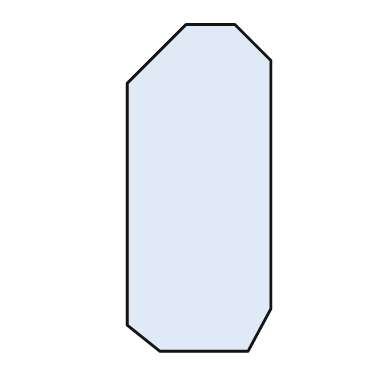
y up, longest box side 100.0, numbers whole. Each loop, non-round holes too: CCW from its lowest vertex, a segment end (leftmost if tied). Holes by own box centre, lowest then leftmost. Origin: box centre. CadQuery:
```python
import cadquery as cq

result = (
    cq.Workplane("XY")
    .moveTo(-12.0, -50.0)
    .lineTo(15.0, -50.0)
    .lineTo(22.0, -37.0)
    .lineTo(22.0, 39.0)
    .lineTo(11.0, 50.0)
    .lineTo(-4.0, 50.0)
    .lineTo(-22.0, 32.0)
    .lineTo(-22.0, -42.0)
    .close()
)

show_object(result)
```